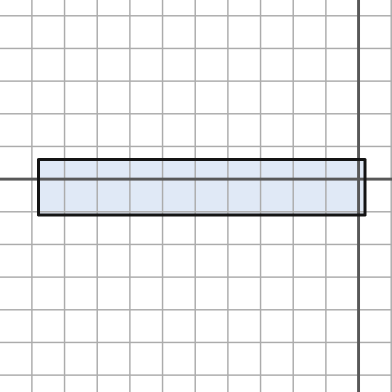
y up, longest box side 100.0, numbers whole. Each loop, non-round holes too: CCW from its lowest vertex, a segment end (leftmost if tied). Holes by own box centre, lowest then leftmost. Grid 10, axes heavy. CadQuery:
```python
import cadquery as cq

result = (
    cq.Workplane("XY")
    .moveTo(-98.0, -11.0)
    .lineTo(2.0, -11.0)
    .lineTo(2.0, 6.0)
    .lineTo(-98.0, 6.0)
    .close()
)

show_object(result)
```